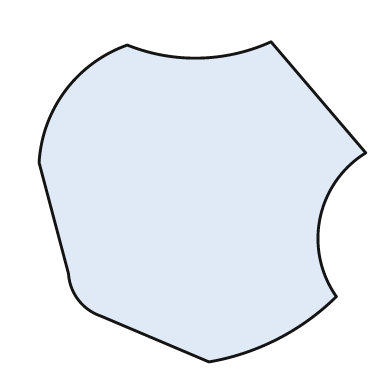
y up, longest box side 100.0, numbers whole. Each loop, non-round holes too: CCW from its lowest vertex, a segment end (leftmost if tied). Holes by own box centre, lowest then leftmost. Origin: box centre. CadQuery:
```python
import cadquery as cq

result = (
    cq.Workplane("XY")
    .moveTo(2.0, -49.0)
    .threePointArc((23.0, -42.0), (41.0, -29.0))
    .threePointArc((36.0, -5.0), (50.0, 15.0))
    .lineTo(21.0, 49.0)
    .threePointArc((-1.0, 44.0), (-23.0, 48.0))
    .threePointArc((-42.0, 34.0), (-50.0, 12.0))
    .lineTo(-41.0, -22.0)
    .threePointArc((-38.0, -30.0), (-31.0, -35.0))
    .close()
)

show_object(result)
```